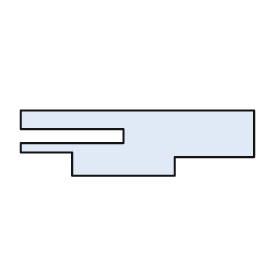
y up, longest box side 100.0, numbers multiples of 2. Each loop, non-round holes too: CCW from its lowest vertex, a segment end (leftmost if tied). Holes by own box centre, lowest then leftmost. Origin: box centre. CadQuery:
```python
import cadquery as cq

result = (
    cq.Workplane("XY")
    .moveTo(-28.0, -14.0)
    .lineTo(16.0, -14.0)
    .lineTo(16.0, -6.0)
    .lineTo(50.0, -6.0)
    .lineTo(50.0, 14.0)
    .lineTo(-50.0, 14.0)
    .lineTo(-50.0, 6.0)
    .lineTo(-6.0, 6.0)
    .lineTo(-6.0, 0.0)
    .lineTo(-50.0, 0.0)
    .lineTo(-50.0, -4.0)
    .lineTo(-28.0, -4.0)
    .close()
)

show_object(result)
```